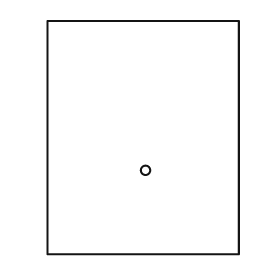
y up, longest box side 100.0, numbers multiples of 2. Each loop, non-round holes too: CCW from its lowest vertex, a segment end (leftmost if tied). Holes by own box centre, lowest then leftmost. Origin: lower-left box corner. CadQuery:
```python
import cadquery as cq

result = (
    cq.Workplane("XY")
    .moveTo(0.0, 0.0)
    .lineTo(82.0, 0.0)
    .lineTo(82.0, 100.0)
    .lineTo(0.0, 100.0)
    .close()
    .moveTo(42.0, 36.0)
    .circle(2.0)
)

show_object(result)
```